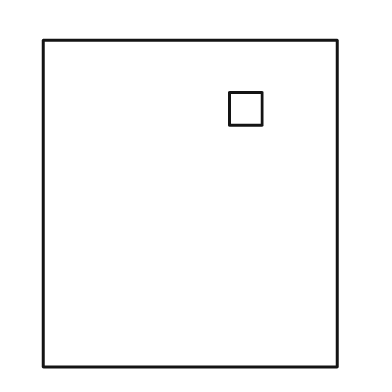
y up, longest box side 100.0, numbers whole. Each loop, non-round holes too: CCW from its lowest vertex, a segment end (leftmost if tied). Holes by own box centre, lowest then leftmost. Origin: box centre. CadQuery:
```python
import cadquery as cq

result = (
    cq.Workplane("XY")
    .moveTo(-45.0, -50.0)
    .lineTo(45.0, -50.0)
    .lineTo(45.0, 50.0)
    .lineTo(-45.0, 50.0)
    .close()
    .moveTo(12.0, 24.0)
    .lineTo(22.0, 24.0)
    .lineTo(22.0, 34.0)
    .lineTo(12.0, 34.0)
    .close()
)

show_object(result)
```